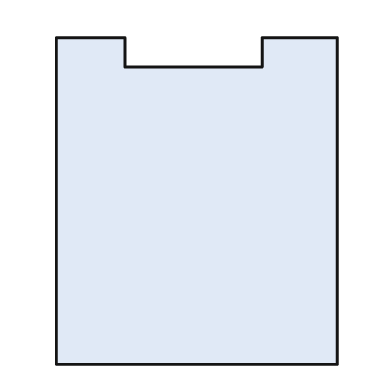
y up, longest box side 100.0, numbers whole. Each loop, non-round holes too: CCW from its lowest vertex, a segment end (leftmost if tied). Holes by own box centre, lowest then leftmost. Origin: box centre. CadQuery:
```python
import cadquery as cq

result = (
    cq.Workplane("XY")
    .moveTo(-43.0, -50.0)
    .lineTo(43.0, -50.0)
    .lineTo(43.0, 50.0)
    .lineTo(20.0, 50.0)
    .lineTo(20.0, 41.0)
    .lineTo(-22.0, 41.0)
    .lineTo(-22.0, 50.0)
    .lineTo(-43.0, 50.0)
    .close()
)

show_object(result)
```